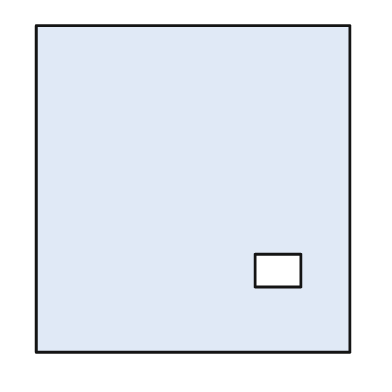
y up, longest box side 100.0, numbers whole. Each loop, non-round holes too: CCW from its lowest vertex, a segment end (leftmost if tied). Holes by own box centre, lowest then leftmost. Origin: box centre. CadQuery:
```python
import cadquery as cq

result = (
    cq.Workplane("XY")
    .moveTo(-48.0, -50.0)
    .lineTo(48.0, -50.0)
    .lineTo(48.0, 50.0)
    .lineTo(-48.0, 50.0)
    .close()
    .moveTo(19.0, -30.0)
    .lineTo(33.0, -30.0)
    .lineTo(33.0, -20.0)
    .lineTo(19.0, -20.0)
    .close()
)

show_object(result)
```